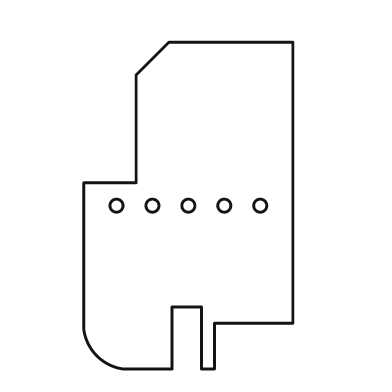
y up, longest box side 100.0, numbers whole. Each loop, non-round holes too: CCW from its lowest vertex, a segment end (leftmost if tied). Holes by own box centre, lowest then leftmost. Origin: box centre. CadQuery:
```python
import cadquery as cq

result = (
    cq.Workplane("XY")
    .moveTo(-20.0, -50.0)
    .lineTo(-5.0, -50.0)
    .lineTo(-5.0, -31.0)
    .lineTo(4.0, -31.0)
    .lineTo(4.0, -50.0)
    .lineTo(8.0, -50.0)
    .lineTo(8.0, -36.0)
    .lineTo(32.0, -36.0)
    .lineTo(32.0, 50.0)
    .lineTo(-6.0, 50.0)
    .lineTo(-16.0, 40.0)
    .lineTo(-16.0, 7.0)
    .lineTo(-32.0, 7.0)
    .lineTo(-32.0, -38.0)
    .threePointArc((-28.0, -46.0), (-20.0, -50.0))
    .close()
    .moveTo(-22.0, 0.0)
    .circle(2.0)
    .moveTo(-11.0, 0.0)
    .circle(2.0)
    .moveTo(0.0, 0.0)
    .circle(2.0)
    .moveTo(11.0, 0.0)
    .circle(2.0)
    .moveTo(22.0, 0.0)
    .circle(2.0)
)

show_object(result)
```